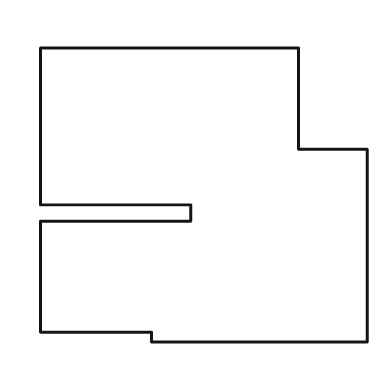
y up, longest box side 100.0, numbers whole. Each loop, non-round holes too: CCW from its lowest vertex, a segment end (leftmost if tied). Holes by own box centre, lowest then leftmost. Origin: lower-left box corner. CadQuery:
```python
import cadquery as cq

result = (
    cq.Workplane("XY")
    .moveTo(34.0, 0.0)
    .lineTo(100.0, 0.0)
    .lineTo(100.0, 59.0)
    .lineTo(79.0, 59.0)
    .lineTo(79.0, 90.0)
    .lineTo(0.0, 90.0)
    .lineTo(0.0, 42.0)
    .lineTo(46.0, 42.0)
    .lineTo(46.0, 37.0)
    .lineTo(0.0, 37.0)
    .lineTo(0.0, 3.0)
    .lineTo(34.0, 3.0)
    .close()
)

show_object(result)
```